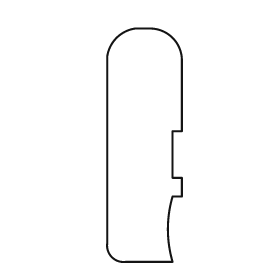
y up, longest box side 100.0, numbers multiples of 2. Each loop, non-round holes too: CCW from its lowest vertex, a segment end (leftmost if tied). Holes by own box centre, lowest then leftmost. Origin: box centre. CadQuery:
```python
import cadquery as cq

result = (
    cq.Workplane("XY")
    .moveTo(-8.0, -50.0)
    .lineTo(12.0, -50.0)
    .threePointArc((10.0, -36.0), (12.0, -22.0))
    .lineTo(16.0, -22.0)
    .lineTo(16.0, -14.0)
    .lineTo(12.0, -14.0)
    .lineTo(12.0, 6.0)
    .lineTo(16.0, 6.0)
    .lineTo(16.0, 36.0)
    .threePointArc((12.0, 46.0), (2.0, 50.0))
    .lineTo(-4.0, 50.0)
    .threePointArc((-12.0, 46.0), (-16.0, 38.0))
    .lineTo(-16.0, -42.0)
    .threePointArc((-14.0, -48.0), (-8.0, -50.0))
    .close()
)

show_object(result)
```